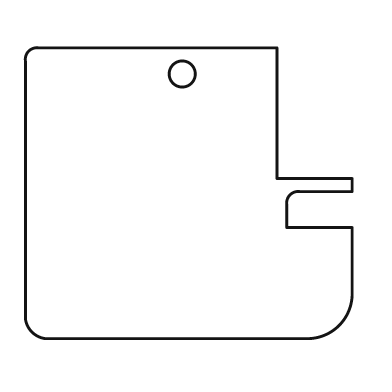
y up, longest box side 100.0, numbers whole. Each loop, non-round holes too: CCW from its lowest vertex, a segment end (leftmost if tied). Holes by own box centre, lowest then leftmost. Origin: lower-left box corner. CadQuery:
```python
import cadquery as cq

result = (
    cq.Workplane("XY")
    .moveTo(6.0, 0.0)
    .lineTo(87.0, 0.0)
    .threePointArc((96.0, 4.0), (100.0, 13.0))
    .lineTo(100.0, 34.0)
    .lineTo(80.0, 34.0)
    .lineTo(80.0, 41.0)
    .threePointArc((81.0, 44.0), (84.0, 45.0))
    .lineTo(100.0, 45.0)
    .lineTo(100.0, 49.0)
    .lineTo(77.0, 49.0)
    .lineTo(77.0, 89.0)
    .lineTo(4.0, 89.0)
    .threePointArc((1.0, 88.0), (0.0, 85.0))
    .lineTo(0.0, 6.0)
    .threePointArc((2.0, 2.0), (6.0, 0.0))
    .close()
    .moveTo(48.0, 81.0)
    .circle(4.0)
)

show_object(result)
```